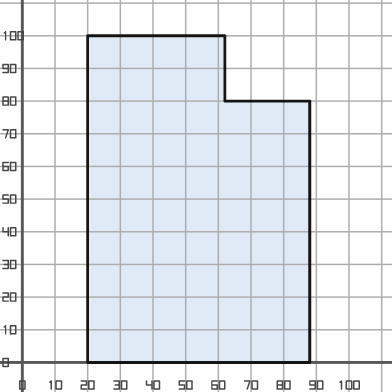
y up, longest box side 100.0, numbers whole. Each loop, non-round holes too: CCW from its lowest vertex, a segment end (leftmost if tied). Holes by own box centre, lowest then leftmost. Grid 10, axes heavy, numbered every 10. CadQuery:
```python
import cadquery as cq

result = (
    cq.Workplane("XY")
    .moveTo(20.0, 0.0)
    .lineTo(88.0, 0.0)
    .lineTo(88.0, 80.0)
    .lineTo(62.0, 80.0)
    .lineTo(62.0, 100.0)
    .lineTo(20.0, 100.0)
    .close()
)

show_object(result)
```